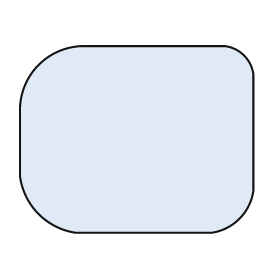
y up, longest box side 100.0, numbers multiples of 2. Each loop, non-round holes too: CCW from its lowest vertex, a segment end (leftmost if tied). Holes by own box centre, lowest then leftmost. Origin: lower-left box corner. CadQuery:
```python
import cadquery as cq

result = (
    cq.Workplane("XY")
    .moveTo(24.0, 0.0)
    .lineTo(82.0, 0.0)
    .threePointArc((94.0, 6.0), (100.0, 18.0))
    .lineTo(100.0, 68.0)
    .threePointArc((96.0, 76.0), (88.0, 80.0))
    .lineTo(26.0, 80.0)
    .threePointArc((8.0, 72.0), (0.0, 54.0))
    .lineTo(0.0, 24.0)
    .threePointArc((8.0, 8.0), (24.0, 0.0))
    .close()
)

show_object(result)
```